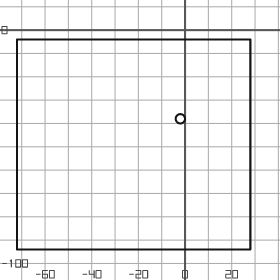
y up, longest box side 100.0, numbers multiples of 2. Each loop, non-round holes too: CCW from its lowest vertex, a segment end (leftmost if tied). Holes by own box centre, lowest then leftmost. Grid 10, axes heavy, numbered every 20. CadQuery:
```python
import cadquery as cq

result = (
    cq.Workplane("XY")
    .moveTo(-72.0, -94.0)
    .lineTo(28.0, -94.0)
    .lineTo(28.0, -4.0)
    .lineTo(-72.0, -4.0)
    .close()
    .moveTo(-2.0, -38.0)
    .circle(2.0)
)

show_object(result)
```